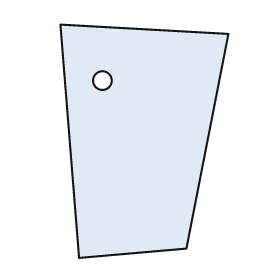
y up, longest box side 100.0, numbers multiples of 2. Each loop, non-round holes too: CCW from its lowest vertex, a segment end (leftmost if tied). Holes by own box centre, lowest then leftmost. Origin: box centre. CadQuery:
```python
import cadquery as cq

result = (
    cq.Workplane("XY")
    .moveTo(-28.0, -50.0)
    .lineTo(18.0, -46.0)
    .lineTo(36.0, 46.0)
    .lineTo(-36.0, 50.0)
    .close()
    .moveTo(-18.0, 26.0)
    .circle(4.0)
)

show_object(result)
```